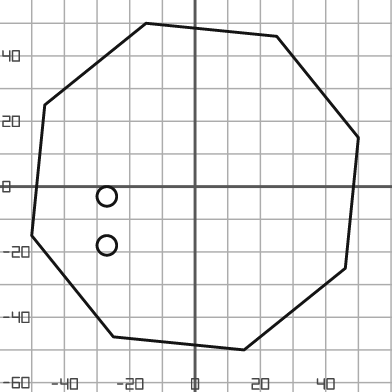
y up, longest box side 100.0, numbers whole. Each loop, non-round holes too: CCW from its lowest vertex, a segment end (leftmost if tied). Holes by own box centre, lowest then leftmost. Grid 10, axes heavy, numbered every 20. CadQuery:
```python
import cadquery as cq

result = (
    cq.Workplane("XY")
    .moveTo(15.0, -50.0)
    .lineTo(46.0, -25.0)
    .lineTo(50.0, 15.0)
    .lineTo(25.0, 46.0)
    .lineTo(-15.0, 50.0)
    .lineTo(-46.0, 25.0)
    .lineTo(-50.0, -15.0)
    .lineTo(-25.0, -46.0)
    .close()
    .moveTo(-27.0, -18.0)
    .circle(3.0)
    .moveTo(-27.0, -3.0)
    .circle(3.0)
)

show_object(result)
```